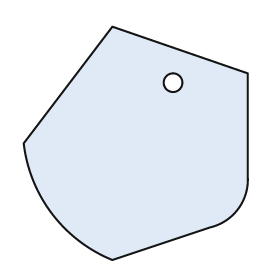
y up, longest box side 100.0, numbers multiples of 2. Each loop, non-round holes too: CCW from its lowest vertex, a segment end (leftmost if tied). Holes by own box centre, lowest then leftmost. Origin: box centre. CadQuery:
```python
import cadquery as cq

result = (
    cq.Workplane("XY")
    .moveTo(-10.0, -50.0)
    .lineTo(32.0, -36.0)
    .threePointArc((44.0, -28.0), (48.0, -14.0))
    .lineTo(48.0, 30.0)
    .lineTo(-10.0, 50.0)
    .lineTo(-48.0, 0.0)
    .threePointArc((-36.0, -30.0), (-10.0, -50.0))
    .close()
    .moveTo(16.0, 26.0)
    .circle(4.0)
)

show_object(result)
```